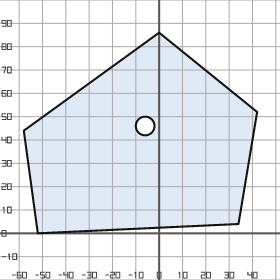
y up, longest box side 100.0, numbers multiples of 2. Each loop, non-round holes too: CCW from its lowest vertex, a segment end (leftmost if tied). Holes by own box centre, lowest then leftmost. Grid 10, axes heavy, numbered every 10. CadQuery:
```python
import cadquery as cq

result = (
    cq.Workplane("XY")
    .moveTo(-52.0, 0.0)
    .lineTo(34.0, 4.0)
    .lineTo(42.0, 52.0)
    .lineTo(0.0, 86.0)
    .lineTo(-58.0, 44.0)
    .close()
    .moveTo(-6.0, 46.0)
    .circle(4.0)
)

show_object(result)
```